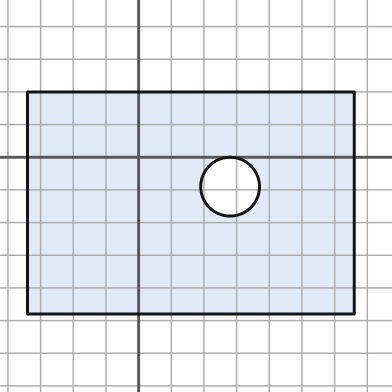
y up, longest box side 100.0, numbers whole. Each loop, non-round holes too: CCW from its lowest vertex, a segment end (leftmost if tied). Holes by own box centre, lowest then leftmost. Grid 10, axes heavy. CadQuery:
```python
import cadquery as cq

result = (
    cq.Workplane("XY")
    .moveTo(-34.0, -48.0)
    .lineTo(66.0, -48.0)
    .lineTo(66.0, 20.0)
    .lineTo(-34.0, 20.0)
    .close()
    .moveTo(28.0, -9.0)
    .circle(9.0)
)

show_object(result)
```